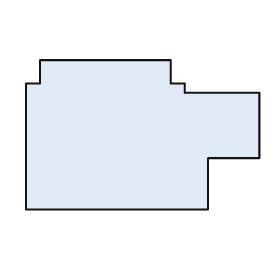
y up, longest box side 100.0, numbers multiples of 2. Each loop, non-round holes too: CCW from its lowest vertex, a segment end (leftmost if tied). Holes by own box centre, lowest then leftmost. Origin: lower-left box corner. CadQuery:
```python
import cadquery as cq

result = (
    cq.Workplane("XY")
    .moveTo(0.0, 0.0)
    .lineTo(78.0, 0.0)
    .lineTo(78.0, 22.0)
    .lineTo(100.0, 22.0)
    .lineTo(100.0, 50.0)
    .lineTo(68.0, 50.0)
    .lineTo(68.0, 54.0)
    .lineTo(62.0, 54.0)
    .lineTo(62.0, 64.0)
    .lineTo(6.0, 64.0)
    .lineTo(6.0, 54.0)
    .lineTo(0.0, 54.0)
    .close()
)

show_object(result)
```